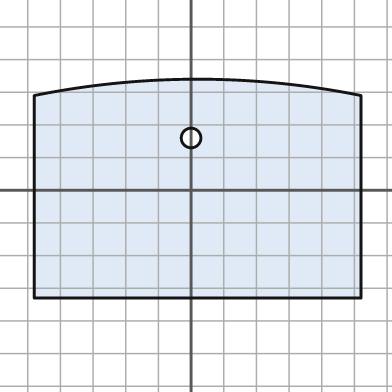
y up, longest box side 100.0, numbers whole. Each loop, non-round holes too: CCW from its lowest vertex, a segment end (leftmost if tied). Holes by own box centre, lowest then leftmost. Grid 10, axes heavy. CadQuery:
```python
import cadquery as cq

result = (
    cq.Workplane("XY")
    .moveTo(-48.0, -33.0)
    .lineTo(52.0, -33.0)
    .lineTo(52.0, 29.0)
    .threePointArc((2.0, 34.0), (-48.0, 29.0))
    .close()
    .moveTo(0.0, 16.0)
    .circle(3.0)
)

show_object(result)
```